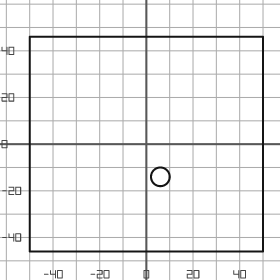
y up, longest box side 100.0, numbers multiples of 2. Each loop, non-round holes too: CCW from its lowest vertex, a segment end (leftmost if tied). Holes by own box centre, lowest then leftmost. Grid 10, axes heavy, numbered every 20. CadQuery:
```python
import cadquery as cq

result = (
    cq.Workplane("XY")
    .moveTo(-50.0, -46.0)
    .lineTo(50.0, -46.0)
    .lineTo(50.0, 46.0)
    .lineTo(-50.0, 46.0)
    .close()
    .moveTo(6.0, -14.0)
    .circle(4.0)
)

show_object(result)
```